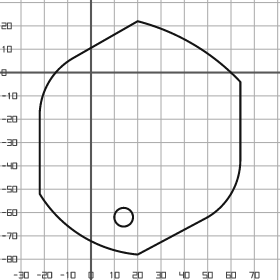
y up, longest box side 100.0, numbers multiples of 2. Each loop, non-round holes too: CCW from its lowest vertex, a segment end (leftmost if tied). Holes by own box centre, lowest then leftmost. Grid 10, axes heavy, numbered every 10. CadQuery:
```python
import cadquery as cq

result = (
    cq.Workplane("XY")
    .moveTo(20.0, -78.0)
    .lineTo(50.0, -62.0)
    .threePointArc((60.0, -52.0), (64.0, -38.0))
    .lineTo(64.0, -4.0)
    .threePointArc((44.0, 12.0), (20.0, 22.0))
    .lineTo(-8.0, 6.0)
    .threePointArc((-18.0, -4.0), (-22.0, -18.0))
    .lineTo(-22.0, -52.0)
    .threePointArc((-4.0, -70.0), (20.0, -78.0))
    .close()
    .moveTo(14.0, -62.0)
    .circle(4.0)
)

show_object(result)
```